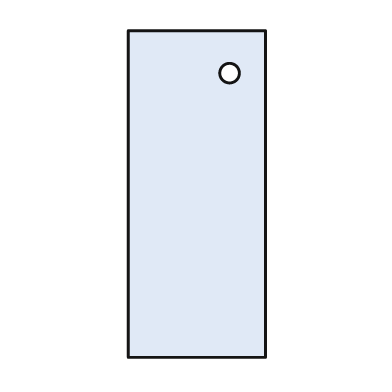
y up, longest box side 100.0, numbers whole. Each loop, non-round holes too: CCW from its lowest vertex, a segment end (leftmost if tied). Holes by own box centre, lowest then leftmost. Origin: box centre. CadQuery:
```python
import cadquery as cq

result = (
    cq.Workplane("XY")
    .moveTo(-21.0, -50.0)
    .lineTo(21.0, -50.0)
    .lineTo(21.0, 50.0)
    .lineTo(-21.0, 50.0)
    .close()
    .moveTo(10.0, 37.0)
    .circle(3.0)
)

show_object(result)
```